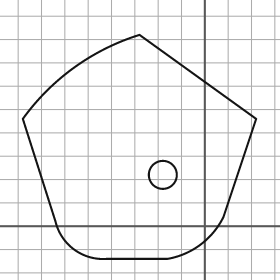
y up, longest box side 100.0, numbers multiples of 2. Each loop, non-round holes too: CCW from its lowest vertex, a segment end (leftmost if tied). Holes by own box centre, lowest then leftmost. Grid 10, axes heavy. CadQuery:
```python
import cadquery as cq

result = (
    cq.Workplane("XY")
    .moveTo(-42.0, -14.0)
    .lineTo(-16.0, -14.0)
    .threePointArc((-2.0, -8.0), (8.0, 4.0))
    .lineTo(22.0, 46.0)
    .lineTo(-28.0, 82.0)
    .threePointArc((-56.0, 68.0), (-78.0, 46.0))
    .lineTo(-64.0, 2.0)
    .threePointArc((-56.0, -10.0), (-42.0, -14.0))
    .close()
    .moveTo(-18.0, 22.0)
    .circle(6.0)
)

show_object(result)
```